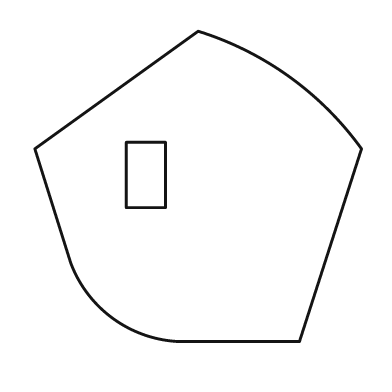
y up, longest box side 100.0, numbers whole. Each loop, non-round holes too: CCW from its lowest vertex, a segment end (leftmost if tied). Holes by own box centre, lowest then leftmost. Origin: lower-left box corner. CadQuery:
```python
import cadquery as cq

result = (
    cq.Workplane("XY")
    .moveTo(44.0, 0.0)
    .lineTo(81.0, 0.0)
    .lineTo(100.0, 59.0)
    .threePointArc((78.0, 81.0), (50.0, 95.0))
    .lineTo(0.0, 59.0)
    .lineTo(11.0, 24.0)
    .threePointArc((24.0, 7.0), (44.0, 0.0))
    .close()
    .moveTo(28.0, 41.0)
    .lineTo(40.0, 41.0)
    .lineTo(40.0, 61.0)
    .lineTo(28.0, 61.0)
    .close()
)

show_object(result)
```